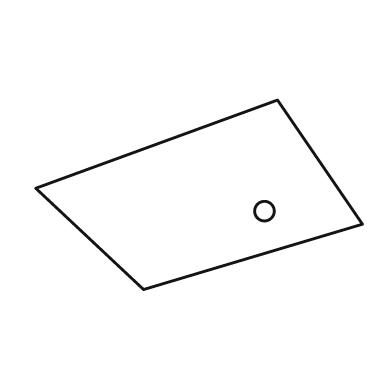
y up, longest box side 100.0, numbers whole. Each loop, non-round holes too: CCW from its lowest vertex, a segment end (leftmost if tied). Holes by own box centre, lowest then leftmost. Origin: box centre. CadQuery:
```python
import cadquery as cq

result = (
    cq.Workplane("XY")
    .moveTo(-17.0, -29.0)
    .lineTo(50.0, -9.0)
    .lineTo(24.0, 29.0)
    .lineTo(-50.0, 2.0)
    .close()
    .moveTo(20.0, -5.0)
    .circle(3.0)
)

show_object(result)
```